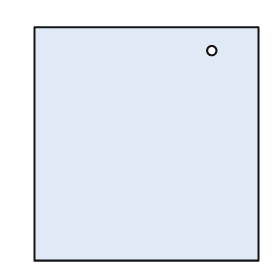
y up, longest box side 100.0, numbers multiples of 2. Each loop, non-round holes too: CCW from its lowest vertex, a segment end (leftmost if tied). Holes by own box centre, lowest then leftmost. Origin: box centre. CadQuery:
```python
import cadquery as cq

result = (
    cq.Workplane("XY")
    .moveTo(-48.0, -50.0)
    .lineTo(48.0, -50.0)
    .lineTo(48.0, 50.0)
    .lineTo(-48.0, 50.0)
    .close()
    .moveTo(28.0, 40.0)
    .circle(2.0)
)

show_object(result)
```